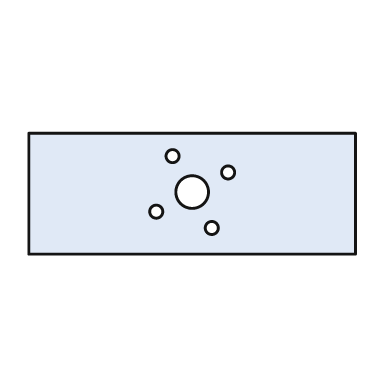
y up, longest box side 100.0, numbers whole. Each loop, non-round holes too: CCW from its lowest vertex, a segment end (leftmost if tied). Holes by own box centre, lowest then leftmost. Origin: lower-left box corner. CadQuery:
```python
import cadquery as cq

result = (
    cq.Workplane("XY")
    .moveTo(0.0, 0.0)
    .lineTo(100.0, 0.0)
    .lineTo(100.0, 37.0)
    .lineTo(0.0, 37.0)
    .close()
    .moveTo(56.0, 8.0)
    .circle(2.0)
    .moveTo(39.0, 13.0)
    .circle(2.0)
    .moveTo(50.0, 19.0)
    .circle(5.0)
    .moveTo(61.0, 25.0)
    .circle(2.0)
    .moveTo(44.0, 30.0)
    .circle(2.0)
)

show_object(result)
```